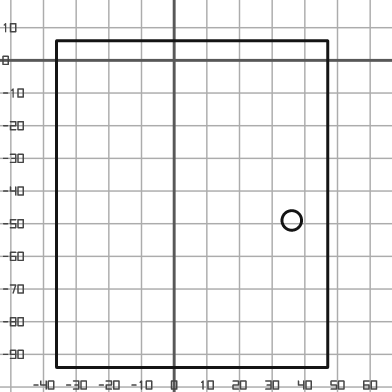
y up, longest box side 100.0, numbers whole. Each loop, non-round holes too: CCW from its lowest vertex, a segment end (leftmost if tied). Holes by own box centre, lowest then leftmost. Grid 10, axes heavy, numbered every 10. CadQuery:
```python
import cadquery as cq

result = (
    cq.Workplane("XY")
    .moveTo(-36.0, -94.0)
    .lineTo(47.0, -94.0)
    .lineTo(47.0, 6.0)
    .lineTo(-36.0, 6.0)
    .close()
    .moveTo(36.0, -49.0)
    .circle(3.0)
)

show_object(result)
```